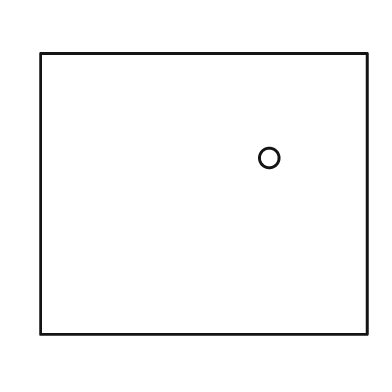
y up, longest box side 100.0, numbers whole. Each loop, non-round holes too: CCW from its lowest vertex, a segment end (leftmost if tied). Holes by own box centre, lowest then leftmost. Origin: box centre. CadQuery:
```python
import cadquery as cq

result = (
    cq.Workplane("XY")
    .moveTo(-50.0, -43.0)
    .lineTo(50.0, -43.0)
    .lineTo(50.0, 43.0)
    .lineTo(-50.0, 43.0)
    .close()
    .moveTo(20.0, 11.0)
    .circle(3.0)
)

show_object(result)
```